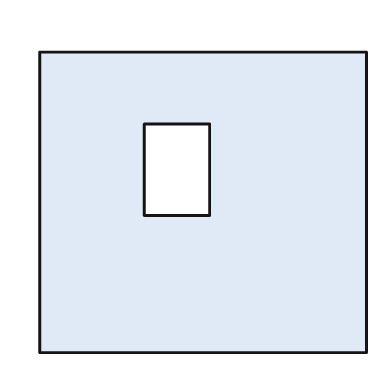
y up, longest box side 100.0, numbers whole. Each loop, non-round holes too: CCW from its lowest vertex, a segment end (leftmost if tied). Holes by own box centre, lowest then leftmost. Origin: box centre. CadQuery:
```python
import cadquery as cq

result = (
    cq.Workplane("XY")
    .moveTo(-50.0, -46.0)
    .lineTo(50.0, -46.0)
    .lineTo(50.0, 46.0)
    .lineTo(-50.0, 46.0)
    .close()
    .moveTo(-18.0, -4.0)
    .lineTo(2.0, -4.0)
    .lineTo(2.0, 24.0)
    .lineTo(-18.0, 24.0)
    .close()
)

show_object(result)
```